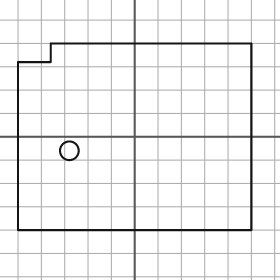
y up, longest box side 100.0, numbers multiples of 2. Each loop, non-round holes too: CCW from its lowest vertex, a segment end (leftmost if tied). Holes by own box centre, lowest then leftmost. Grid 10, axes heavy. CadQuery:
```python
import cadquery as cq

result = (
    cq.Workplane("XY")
    .moveTo(-50.0, -40.0)
    .lineTo(50.0, -40.0)
    .lineTo(50.0, 40.0)
    .lineTo(-36.0, 40.0)
    .lineTo(-36.0, 32.0)
    .lineTo(-50.0, 32.0)
    .close()
    .moveTo(-28.0, -6.0)
    .circle(4.0)
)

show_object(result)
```